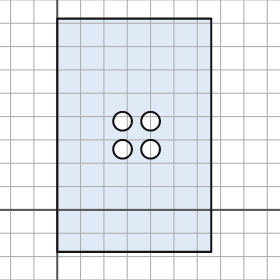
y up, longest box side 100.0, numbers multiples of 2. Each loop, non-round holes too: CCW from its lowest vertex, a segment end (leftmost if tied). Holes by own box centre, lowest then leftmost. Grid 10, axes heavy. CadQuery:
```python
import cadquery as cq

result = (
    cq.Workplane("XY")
    .moveTo(0.0, -18.0)
    .lineTo(66.0, -18.0)
    .lineTo(66.0, 82.0)
    .lineTo(0.0, 82.0)
    .close()
    .moveTo(28.0, 26.0)
    .circle(4.0)
    .moveTo(40.0, 26.0)
    .circle(4.0)
    .moveTo(28.0, 38.0)
    .circle(4.0)
    .moveTo(40.0, 38.0)
    .circle(4.0)
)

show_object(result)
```